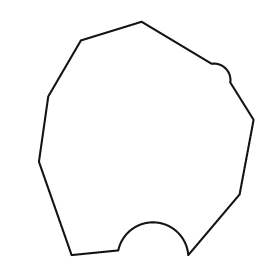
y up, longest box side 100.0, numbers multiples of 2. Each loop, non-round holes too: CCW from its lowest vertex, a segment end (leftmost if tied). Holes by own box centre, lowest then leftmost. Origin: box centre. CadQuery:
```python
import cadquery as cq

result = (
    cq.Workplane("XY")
    .moveTo(-32.0, -50.0)
    .lineTo(-12.0, -48.0)
    .threePointArc((4.0, -36.0), (18.0, -50.0))
    .lineTo(40.0, -24.0)
    .lineTo(46.0, 8.0)
    .lineTo(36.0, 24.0)
    .threePointArc((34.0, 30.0), (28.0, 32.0))
    .lineTo(-2.0, 50.0)
    .lineTo(-28.0, 42.0)
    .lineTo(-42.0, 18.0)
    .lineTo(-46.0, -10.0)
    .close()
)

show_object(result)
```